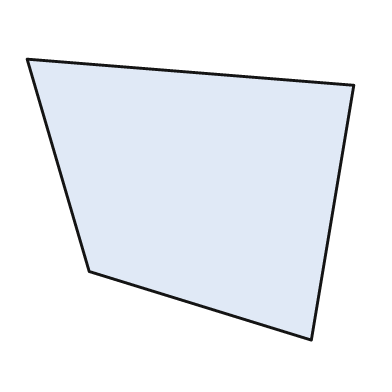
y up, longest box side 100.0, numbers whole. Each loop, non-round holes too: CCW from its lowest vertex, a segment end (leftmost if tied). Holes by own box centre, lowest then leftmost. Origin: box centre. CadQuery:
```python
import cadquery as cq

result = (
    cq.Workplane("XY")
    .moveTo(37.0, -43.0)
    .lineTo(50.0, 35.0)
    .lineTo(-50.0, 43.0)
    .lineTo(-31.0, -22.0)
    .close()
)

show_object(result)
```